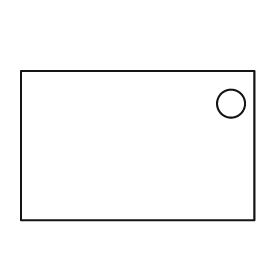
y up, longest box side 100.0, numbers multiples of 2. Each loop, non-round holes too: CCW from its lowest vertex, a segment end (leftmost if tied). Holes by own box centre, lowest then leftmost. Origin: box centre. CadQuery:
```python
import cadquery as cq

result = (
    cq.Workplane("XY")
    .moveTo(-50.0, -32.0)
    .lineTo(50.0, -32.0)
    .lineTo(50.0, 32.0)
    .lineTo(-50.0, 32.0)
    .close()
    .moveTo(40.0, 18.0)
    .circle(6.0)
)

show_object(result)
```